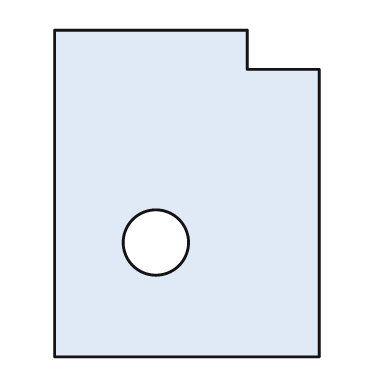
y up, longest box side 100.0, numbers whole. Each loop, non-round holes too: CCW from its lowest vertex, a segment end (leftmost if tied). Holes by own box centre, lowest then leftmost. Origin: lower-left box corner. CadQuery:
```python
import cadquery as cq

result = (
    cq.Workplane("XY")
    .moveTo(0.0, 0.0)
    .lineTo(81.0, 0.0)
    .lineTo(81.0, 88.0)
    .lineTo(59.0, 88.0)
    .lineTo(59.0, 100.0)
    .lineTo(0.0, 100.0)
    .close()
    .moveTo(31.0, 35.0)
    .circle(10.0)
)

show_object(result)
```